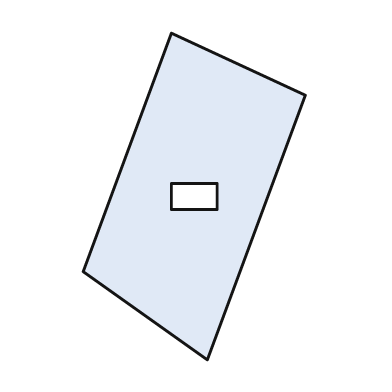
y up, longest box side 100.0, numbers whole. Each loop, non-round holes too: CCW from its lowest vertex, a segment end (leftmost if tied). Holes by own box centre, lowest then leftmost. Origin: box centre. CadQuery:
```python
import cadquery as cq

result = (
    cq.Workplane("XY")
    .moveTo(4.0, -50.0)
    .lineTo(34.0, 31.0)
    .lineTo(-7.0, 50.0)
    .lineTo(-34.0, -23.0)
    .close()
    .moveTo(-7.0, -4.0)
    .lineTo(7.0, -4.0)
    .lineTo(7.0, 4.0)
    .lineTo(-7.0, 4.0)
    .close()
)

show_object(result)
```